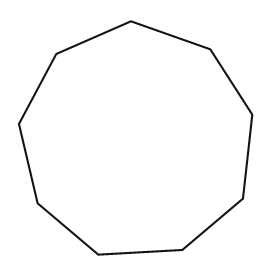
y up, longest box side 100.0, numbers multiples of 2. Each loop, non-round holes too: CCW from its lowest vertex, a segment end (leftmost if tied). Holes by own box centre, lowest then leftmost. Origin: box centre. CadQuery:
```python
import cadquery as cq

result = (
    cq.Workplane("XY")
    .moveTo(-16.0, -50.0)
    .lineTo(20.0, -48.0)
    .lineTo(46.0, -26.0)
    .lineTo(50.0, 10.0)
    .lineTo(32.0, 38.0)
    .lineTo(-2.0, 50.0)
    .lineTo(-34.0, 36.0)
    .lineTo(-50.0, 6.0)
    .lineTo(-42.0, -28.0)
    .close()
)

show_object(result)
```